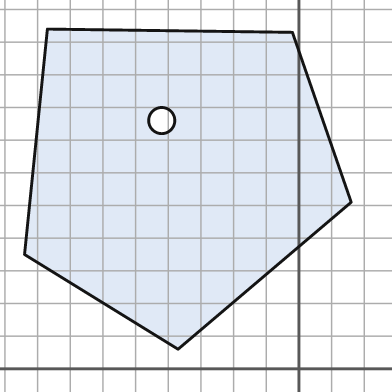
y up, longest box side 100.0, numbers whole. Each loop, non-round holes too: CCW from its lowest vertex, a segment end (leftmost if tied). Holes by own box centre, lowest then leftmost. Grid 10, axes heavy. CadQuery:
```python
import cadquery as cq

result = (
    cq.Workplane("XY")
    .moveTo(-37.0, 6.0)
    .lineTo(16.0, 51.0)
    .lineTo(-2.0, 103.0)
    .lineTo(-77.0, 104.0)
    .lineTo(-84.0, 35.0)
    .close()
    .moveTo(-42.0, 76.0)
    .circle(4.0)
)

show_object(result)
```